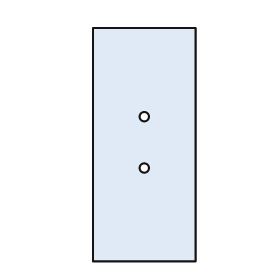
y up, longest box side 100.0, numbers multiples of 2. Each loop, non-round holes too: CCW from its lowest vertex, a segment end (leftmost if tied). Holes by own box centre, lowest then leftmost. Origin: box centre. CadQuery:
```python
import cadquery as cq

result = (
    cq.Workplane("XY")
    .moveTo(-22.0, -50.0)
    .lineTo(22.0, -50.0)
    .lineTo(22.0, 50.0)
    .lineTo(-22.0, 50.0)
    .close()
    .moveTo(0.0, -10.0)
    .circle(2.0)
    .moveTo(0.0, 12.0)
    .circle(2.0)
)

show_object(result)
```